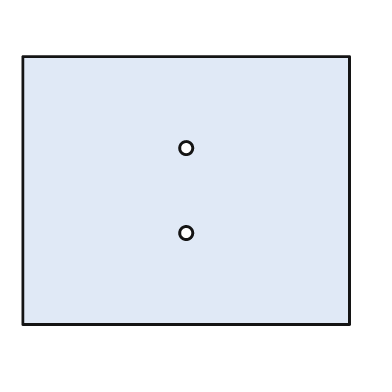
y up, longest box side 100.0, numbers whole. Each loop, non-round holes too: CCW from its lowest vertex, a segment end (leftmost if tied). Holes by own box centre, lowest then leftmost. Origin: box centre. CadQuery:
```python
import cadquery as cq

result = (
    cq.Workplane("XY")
    .moveTo(-50.0, -41.0)
    .lineTo(50.0, -41.0)
    .lineTo(50.0, 41.0)
    .lineTo(-50.0, 41.0)
    .close()
    .moveTo(0.0, -13.0)
    .circle(2.0)
    .moveTo(0.0, 13.0)
    .circle(2.0)
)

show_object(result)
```